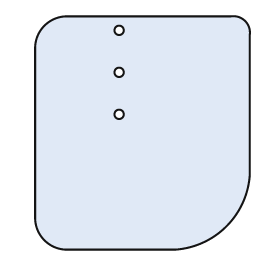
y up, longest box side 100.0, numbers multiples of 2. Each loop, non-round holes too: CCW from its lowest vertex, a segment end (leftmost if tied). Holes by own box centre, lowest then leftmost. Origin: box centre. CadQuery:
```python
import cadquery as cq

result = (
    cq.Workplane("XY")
    .moveTo(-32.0, -50.0)
    .lineTo(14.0, -50.0)
    .threePointArc((36.0, -40.0), (46.0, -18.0))
    .lineTo(46.0, 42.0)
    .threePointArc((44.0, 48.0), (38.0, 50.0))
    .lineTo(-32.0, 50.0)
    .threePointArc((-42.0, 46.0), (-46.0, 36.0))
    .lineTo(-46.0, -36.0)
    .threePointArc((-42.0, -46.0), (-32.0, -50.0))
    .close()
    .moveTo(-10.0, 8.0)
    .circle(2.0)
    .moveTo(-10.0, 26.0)
    .circle(2.0)
    .moveTo(-10.0, 44.0)
    .circle(2.0)
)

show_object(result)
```